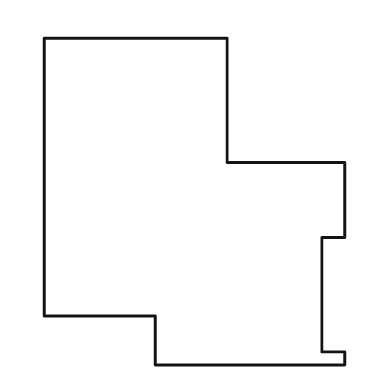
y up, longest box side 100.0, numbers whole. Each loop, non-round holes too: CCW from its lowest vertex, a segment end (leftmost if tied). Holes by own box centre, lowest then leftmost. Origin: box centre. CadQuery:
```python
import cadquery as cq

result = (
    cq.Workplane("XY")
    .moveTo(-12.0, -50.0)
    .lineTo(46.0, -50.0)
    .lineTo(46.0, -46.0)
    .lineTo(39.0, -46.0)
    .lineTo(39.0, -11.0)
    .lineTo(46.0, -11.0)
    .lineTo(46.0, 12.0)
    .lineTo(10.0, 12.0)
    .lineTo(10.0, 50.0)
    .lineTo(-46.0, 50.0)
    .lineTo(-46.0, -35.0)
    .lineTo(-12.0, -35.0)
    .close()
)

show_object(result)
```